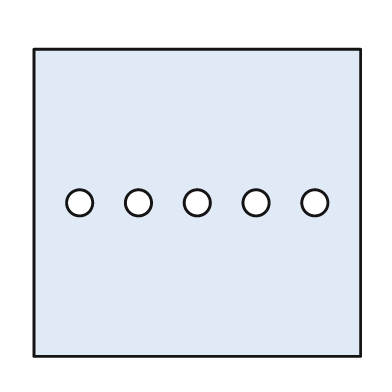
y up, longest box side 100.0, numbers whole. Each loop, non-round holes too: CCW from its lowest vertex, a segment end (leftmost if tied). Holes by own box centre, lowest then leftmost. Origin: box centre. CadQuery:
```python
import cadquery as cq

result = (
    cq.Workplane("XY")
    .moveTo(-50.0, -47.0)
    .lineTo(50.0, -47.0)
    .lineTo(50.0, 47.0)
    .lineTo(-50.0, 47.0)
    .close()
    .moveTo(-36.0, 0.0)
    .circle(4.0)
    .moveTo(-18.0, 0.0)
    .circle(4.0)
    .moveTo(0.0, 0.0)
    .circle(4.0)
    .moveTo(18.0, 0.0)
    .circle(4.0)
    .moveTo(36.0, 0.0)
    .circle(4.0)
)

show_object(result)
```